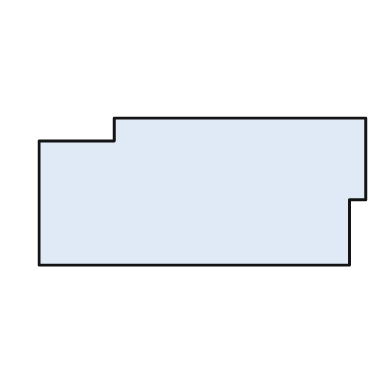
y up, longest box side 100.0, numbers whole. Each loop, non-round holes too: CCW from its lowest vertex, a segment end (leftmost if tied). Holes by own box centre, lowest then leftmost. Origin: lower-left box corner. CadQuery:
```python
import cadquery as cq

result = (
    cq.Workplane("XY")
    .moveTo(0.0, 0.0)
    .lineTo(95.0, 0.0)
    .lineTo(95.0, 20.0)
    .lineTo(100.0, 20.0)
    .lineTo(100.0, 45.0)
    .lineTo(23.0, 45.0)
    .lineTo(23.0, 38.0)
    .lineTo(0.0, 38.0)
    .close()
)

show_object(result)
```